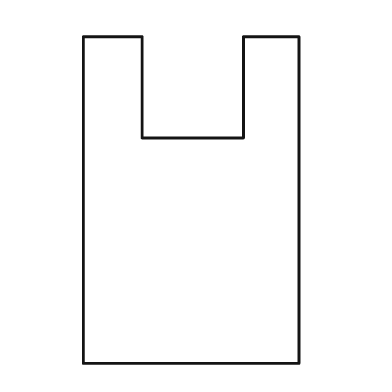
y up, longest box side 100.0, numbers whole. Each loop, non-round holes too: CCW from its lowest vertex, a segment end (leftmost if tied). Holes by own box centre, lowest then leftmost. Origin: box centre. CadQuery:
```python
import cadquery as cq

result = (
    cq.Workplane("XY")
    .moveTo(-33.0, -50.0)
    .lineTo(33.0, -50.0)
    .lineTo(33.0, 50.0)
    .lineTo(16.0, 50.0)
    .lineTo(16.0, 19.0)
    .lineTo(-15.0, 19.0)
    .lineTo(-15.0, 50.0)
    .lineTo(-33.0, 50.0)
    .close()
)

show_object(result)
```